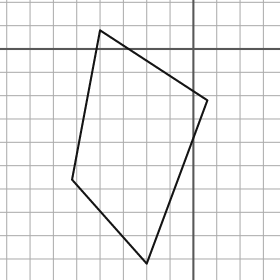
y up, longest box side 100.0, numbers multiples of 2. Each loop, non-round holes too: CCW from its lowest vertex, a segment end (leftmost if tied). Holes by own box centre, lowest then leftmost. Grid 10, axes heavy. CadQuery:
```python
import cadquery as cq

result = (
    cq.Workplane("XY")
    .moveTo(-20.0, -92.0)
    .lineTo(6.0, -22.0)
    .lineTo(-40.0, 8.0)
    .lineTo(-52.0, -56.0)
    .close()
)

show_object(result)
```